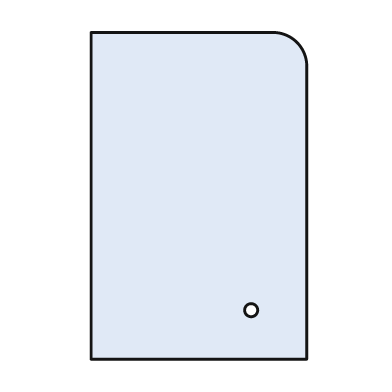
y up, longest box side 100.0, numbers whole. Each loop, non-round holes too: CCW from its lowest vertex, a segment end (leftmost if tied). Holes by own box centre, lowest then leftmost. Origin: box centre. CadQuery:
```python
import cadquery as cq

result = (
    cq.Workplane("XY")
    .moveTo(-33.0, -50.0)
    .lineTo(33.0, -50.0)
    .lineTo(33.0, 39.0)
    .threePointArc((30.0, 47.0), (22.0, 50.0))
    .lineTo(-33.0, 50.0)
    .close()
    .moveTo(16.0, -35.0)
    .circle(2.0)
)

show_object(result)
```